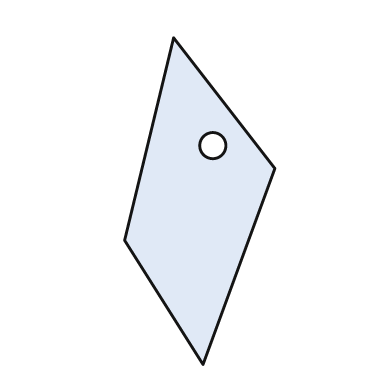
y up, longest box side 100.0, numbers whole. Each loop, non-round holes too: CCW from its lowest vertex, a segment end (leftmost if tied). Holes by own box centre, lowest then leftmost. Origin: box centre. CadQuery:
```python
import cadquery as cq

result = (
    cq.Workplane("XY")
    .moveTo(1.0, -50.0)
    .lineTo(23.0, 10.0)
    .lineTo(-8.0, 50.0)
    .lineTo(-23.0, -12.0)
    .close()
    .moveTo(4.0, 17.0)
    .circle(4.0)
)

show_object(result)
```